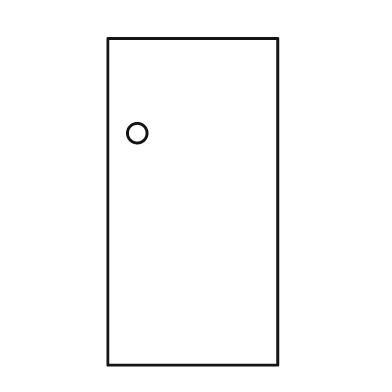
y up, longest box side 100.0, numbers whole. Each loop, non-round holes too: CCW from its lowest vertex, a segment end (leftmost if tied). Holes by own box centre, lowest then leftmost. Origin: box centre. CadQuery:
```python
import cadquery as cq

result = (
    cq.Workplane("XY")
    .moveTo(-26.0, -50.0)
    .lineTo(26.0, -50.0)
    .lineTo(26.0, 50.0)
    .lineTo(-26.0, 50.0)
    .close()
    .moveTo(-17.0, 21.0)
    .circle(3.0)
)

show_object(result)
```